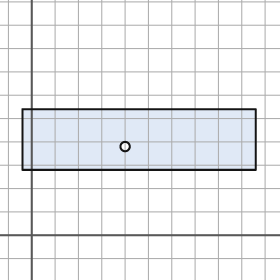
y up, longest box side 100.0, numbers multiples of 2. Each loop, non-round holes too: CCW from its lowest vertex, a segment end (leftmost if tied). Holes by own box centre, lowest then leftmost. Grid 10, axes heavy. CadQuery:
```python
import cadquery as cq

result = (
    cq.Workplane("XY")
    .moveTo(-4.0, 28.0)
    .lineTo(96.0, 28.0)
    .lineTo(96.0, 54.0)
    .lineTo(-4.0, 54.0)
    .close()
    .moveTo(40.0, 38.0)
    .circle(2.0)
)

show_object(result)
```